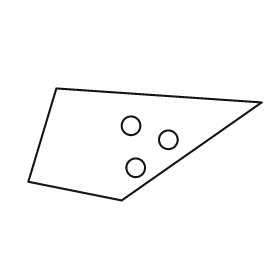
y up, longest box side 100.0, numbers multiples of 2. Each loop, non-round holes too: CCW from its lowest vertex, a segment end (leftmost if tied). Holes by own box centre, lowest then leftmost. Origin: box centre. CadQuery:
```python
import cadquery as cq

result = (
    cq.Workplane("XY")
    .moveTo(-10.0, -24.0)
    .lineTo(50.0, 18.0)
    .lineTo(-38.0, 24.0)
    .lineTo(-50.0, -16.0)
    .close()
    .moveTo(-4.0, -10.0)
    .circle(4.0)
    .moveTo(10.0, 2.0)
    .circle(4.0)
    .moveTo(-6.0, 8.0)
    .circle(4.0)
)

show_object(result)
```